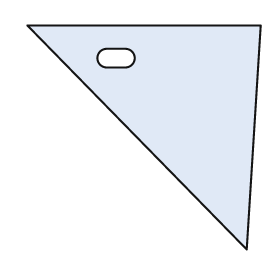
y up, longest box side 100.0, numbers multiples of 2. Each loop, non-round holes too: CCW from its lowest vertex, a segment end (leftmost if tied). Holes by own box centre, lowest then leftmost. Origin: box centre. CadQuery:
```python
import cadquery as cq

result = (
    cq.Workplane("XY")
    .moveTo(44.0, -48.0)
    .lineTo(50.0, 48.0)
    .lineTo(-50.0, 48.0)
    .close()
    .moveTo(-16.0, 30.0)
    .lineTo(-8.0, 30.0)
    .threePointArc((-4.0, 34.0), (-8.0, 38.0))
    .lineTo(-16.0, 38.0)
    .threePointArc((-20.0, 34.0), (-16.0, 30.0))
    .close()
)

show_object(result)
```